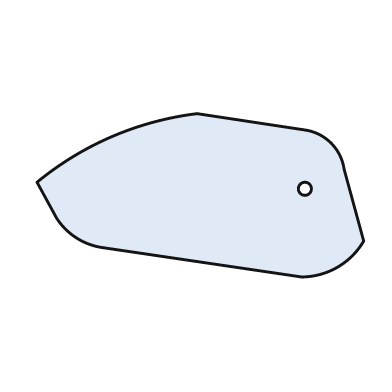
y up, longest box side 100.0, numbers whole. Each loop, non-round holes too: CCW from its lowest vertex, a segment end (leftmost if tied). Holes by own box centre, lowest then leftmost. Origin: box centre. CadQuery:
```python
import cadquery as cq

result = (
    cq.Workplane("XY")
    .moveTo(31.0, -25.0)
    .threePointArc((42.0, -22.0), (50.0, -14.0))
    .lineTo(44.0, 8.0)
    .threePointArc((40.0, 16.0), (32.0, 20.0))
    .lineTo(-1.0, 25.0)
    .threePointArc((-27.0, 18.0), (-50.0, 4.0))
    .lineTo(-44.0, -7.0)
    .threePointArc((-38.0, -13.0), (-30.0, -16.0))
    .close()
    .moveTo(32.0, 2.0)
    .circle(2.0)
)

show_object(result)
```